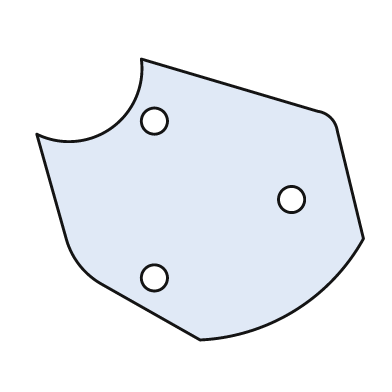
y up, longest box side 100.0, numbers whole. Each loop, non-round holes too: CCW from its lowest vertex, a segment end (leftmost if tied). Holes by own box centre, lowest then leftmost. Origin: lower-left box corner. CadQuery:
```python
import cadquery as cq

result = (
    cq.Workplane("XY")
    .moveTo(50.0, 0.0)
    .threePointArc((79.0, 9.0), (100.0, 31.0))
    .lineTo(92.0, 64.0)
    .threePointArc((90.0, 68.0), (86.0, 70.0))
    .lineTo(32.0, 86.0)
    .threePointArc((23.0, 65.0), (0.0, 63.0))
    .lineTo(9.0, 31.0)
    .threePointArc((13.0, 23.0), (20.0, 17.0))
    .close()
    .moveTo(36.0, 19.0)
    .circle(4.0)
    .moveTo(78.0, 43.0)
    .circle(4.0)
    .moveTo(36.0, 67.0)
    .circle(4.0)
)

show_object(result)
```